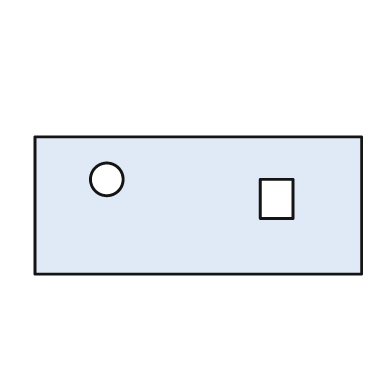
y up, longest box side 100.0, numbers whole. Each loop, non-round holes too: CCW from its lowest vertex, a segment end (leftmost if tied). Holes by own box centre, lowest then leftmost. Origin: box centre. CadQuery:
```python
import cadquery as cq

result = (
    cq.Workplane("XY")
    .moveTo(-50.0, -21.0)
    .lineTo(50.0, -21.0)
    .lineTo(50.0, 21.0)
    .lineTo(-50.0, 21.0)
    .close()
    .moveTo(19.0, -4.0)
    .lineTo(29.0, -4.0)
    .lineTo(29.0, 8.0)
    .lineTo(19.0, 8.0)
    .close()
    .moveTo(-28.0, 8.0)
    .circle(5.0)
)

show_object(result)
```